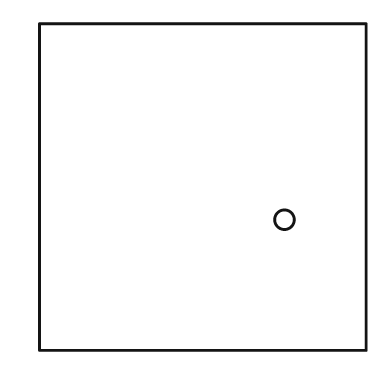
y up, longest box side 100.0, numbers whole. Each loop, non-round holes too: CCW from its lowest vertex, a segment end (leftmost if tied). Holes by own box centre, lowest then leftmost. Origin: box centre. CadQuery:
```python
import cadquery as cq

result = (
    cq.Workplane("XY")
    .moveTo(-50.0, -50.0)
    .lineTo(50.0, -50.0)
    .lineTo(50.0, 50.0)
    .lineTo(-50.0, 50.0)
    .close()
    .moveTo(25.0, -10.0)
    .circle(3.0)
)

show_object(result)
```